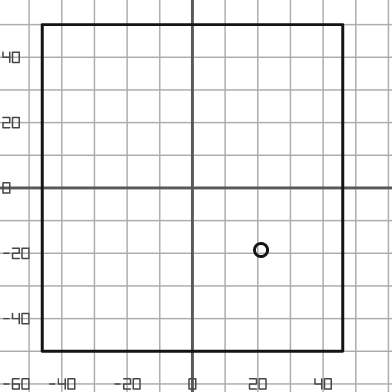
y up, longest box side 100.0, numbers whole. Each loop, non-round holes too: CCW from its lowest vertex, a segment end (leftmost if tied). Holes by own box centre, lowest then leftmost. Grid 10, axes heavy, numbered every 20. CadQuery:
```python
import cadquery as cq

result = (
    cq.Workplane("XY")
    .moveTo(-46.0, -50.0)
    .lineTo(46.0, -50.0)
    .lineTo(46.0, 50.0)
    .lineTo(-46.0, 50.0)
    .close()
    .moveTo(21.0, -19.0)
    .circle(2.0)
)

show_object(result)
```